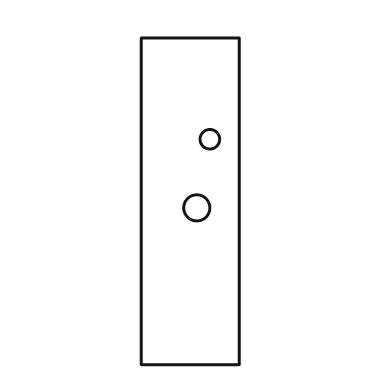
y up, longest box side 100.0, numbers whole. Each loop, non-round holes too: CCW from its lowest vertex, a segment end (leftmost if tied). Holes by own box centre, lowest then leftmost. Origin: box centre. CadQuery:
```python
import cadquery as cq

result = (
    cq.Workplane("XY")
    .moveTo(-15.0, -50.0)
    .lineTo(15.0, -50.0)
    .lineTo(15.0, 50.0)
    .lineTo(-15.0, 50.0)
    .close()
    .moveTo(2.0, -2.0)
    .circle(4.0)
    .moveTo(6.0, 19.0)
    .circle(3.0)
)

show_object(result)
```